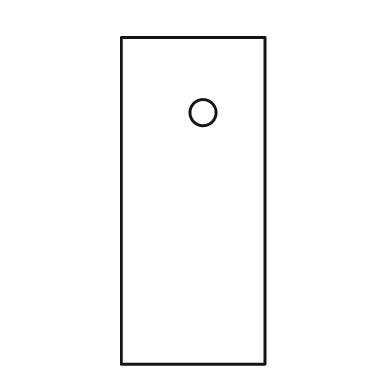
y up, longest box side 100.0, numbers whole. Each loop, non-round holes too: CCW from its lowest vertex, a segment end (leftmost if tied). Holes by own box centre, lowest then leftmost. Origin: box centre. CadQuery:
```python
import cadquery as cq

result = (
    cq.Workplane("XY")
    .moveTo(-22.0, -50.0)
    .lineTo(22.0, -50.0)
    .lineTo(22.0, 50.0)
    .lineTo(-22.0, 50.0)
    .close()
    .moveTo(3.0, 27.0)
    .circle(4.0)
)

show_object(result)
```